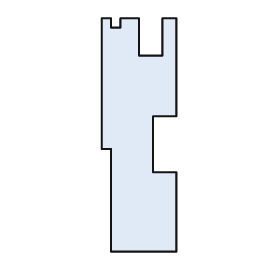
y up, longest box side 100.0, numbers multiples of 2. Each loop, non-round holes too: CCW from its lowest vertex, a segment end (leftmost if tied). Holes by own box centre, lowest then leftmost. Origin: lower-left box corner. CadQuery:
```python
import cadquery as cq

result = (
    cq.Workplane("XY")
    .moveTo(4.0, 0.0)
    .lineTo(32.0, 0.0)
    .lineTo(32.0, 34.0)
    .lineTo(22.0, 34.0)
    .lineTo(22.0, 58.0)
    .lineTo(32.0, 58.0)
    .lineTo(32.0, 100.0)
    .lineTo(26.0, 100.0)
    .lineTo(26.0, 84.0)
    .lineTo(16.0, 84.0)
    .lineTo(16.0, 100.0)
    .lineTo(8.0, 100.0)
    .lineTo(8.0, 96.0)
    .lineTo(4.0, 96.0)
    .lineTo(4.0, 100.0)
    .lineTo(0.0, 100.0)
    .lineTo(0.0, 44.0)
    .lineTo(4.0, 44.0)
    .close()
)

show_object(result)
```